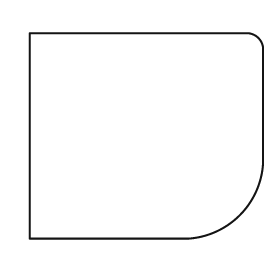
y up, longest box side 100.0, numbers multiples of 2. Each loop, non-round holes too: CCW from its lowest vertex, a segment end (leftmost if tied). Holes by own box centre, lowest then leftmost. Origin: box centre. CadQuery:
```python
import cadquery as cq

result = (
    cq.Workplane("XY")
    .moveTo(-50.0, -44.0)
    .lineTo(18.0, -44.0)
    .threePointArc((40.0, -34.0), (50.0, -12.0))
    .lineTo(50.0, 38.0)
    .threePointArc((48.0, 42.0), (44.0, 44.0))
    .lineTo(-50.0, 44.0)
    .close()
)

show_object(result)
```